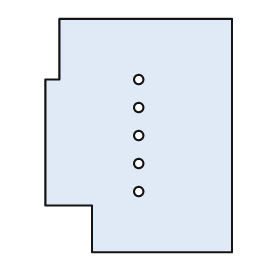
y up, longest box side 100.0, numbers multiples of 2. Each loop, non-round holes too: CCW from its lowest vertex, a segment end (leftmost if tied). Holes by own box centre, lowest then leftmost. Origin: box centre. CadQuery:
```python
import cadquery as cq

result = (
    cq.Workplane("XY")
    .moveTo(-20.0, -50.0)
    .lineTo(40.0, -50.0)
    .lineTo(40.0, 50.0)
    .lineTo(-34.0, 50.0)
    .lineTo(-34.0, 24.0)
    .lineTo(-40.0, 24.0)
    .lineTo(-40.0, -30.0)
    .lineTo(-20.0, -30.0)
    .close()
    .moveTo(0.0, -24.0)
    .circle(2.0)
    .moveTo(0.0, -12.0)
    .circle(2.0)
    .moveTo(0.0, 0.0)
    .circle(2.0)
    .moveTo(0.0, 12.0)
    .circle(2.0)
    .moveTo(0.0, 24.0)
    .circle(2.0)
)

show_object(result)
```